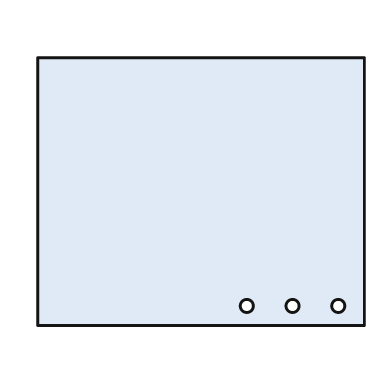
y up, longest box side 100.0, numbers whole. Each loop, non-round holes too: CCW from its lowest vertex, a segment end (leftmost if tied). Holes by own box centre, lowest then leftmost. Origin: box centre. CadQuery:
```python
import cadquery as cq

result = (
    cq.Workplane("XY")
    .moveTo(-50.0, -41.0)
    .lineTo(50.0, -41.0)
    .lineTo(50.0, 41.0)
    .lineTo(-50.0, 41.0)
    .close()
    .moveTo(14.0, -35.0)
    .circle(2.0)
    .moveTo(28.0, -35.0)
    .circle(2.0)
    .moveTo(42.0, -35.0)
    .circle(2.0)
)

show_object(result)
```